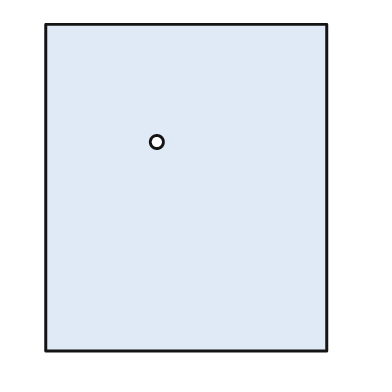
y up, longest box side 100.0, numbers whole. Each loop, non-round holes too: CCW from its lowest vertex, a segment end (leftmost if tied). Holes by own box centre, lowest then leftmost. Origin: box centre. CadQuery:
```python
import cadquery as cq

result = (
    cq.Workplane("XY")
    .moveTo(-43.0, -50.0)
    .lineTo(43.0, -50.0)
    .lineTo(43.0, 50.0)
    .lineTo(-43.0, 50.0)
    .close()
    .moveTo(-9.0, 14.0)
    .circle(2.0)
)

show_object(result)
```